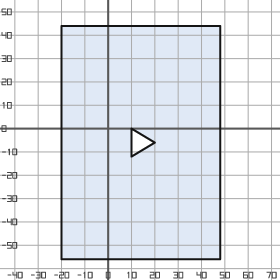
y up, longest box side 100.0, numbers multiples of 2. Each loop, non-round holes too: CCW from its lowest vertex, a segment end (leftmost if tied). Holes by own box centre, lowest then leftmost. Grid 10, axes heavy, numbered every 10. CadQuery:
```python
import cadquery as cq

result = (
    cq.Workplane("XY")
    .moveTo(-20.0, -56.0)
    .lineTo(48.0, -56.0)
    .lineTo(48.0, 44.0)
    .lineTo(-20.0, 44.0)
    .close()
    .moveTo(10.0, -12.0)
    .lineTo(20.0, -6.0)
    .lineTo(10.0, 0.0)
    .close()
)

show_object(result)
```